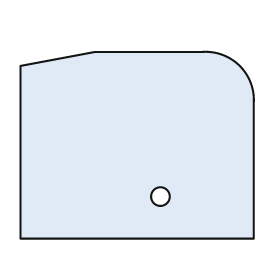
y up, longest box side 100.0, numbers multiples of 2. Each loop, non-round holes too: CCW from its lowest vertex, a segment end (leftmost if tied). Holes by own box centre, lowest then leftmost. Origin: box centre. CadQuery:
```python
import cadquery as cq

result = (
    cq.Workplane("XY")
    .moveTo(-50.0, -40.0)
    .lineTo(50.0, -40.0)
    .lineTo(50.0, 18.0)
    .threePointArc((44.0, 34.0), (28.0, 40.0))
    .lineTo(-18.0, 40.0)
    .lineTo(-50.0, 34.0)
    .close()
    .moveTo(10.0, -22.0)
    .circle(4.0)
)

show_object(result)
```